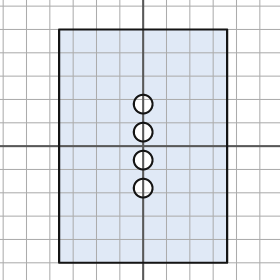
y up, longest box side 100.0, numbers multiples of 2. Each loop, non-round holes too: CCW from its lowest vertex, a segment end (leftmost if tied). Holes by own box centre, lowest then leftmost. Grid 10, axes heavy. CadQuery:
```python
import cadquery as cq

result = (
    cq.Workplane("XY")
    .moveTo(-36.0, -50.0)
    .lineTo(36.0, -50.0)
    .lineTo(36.0, 50.0)
    .lineTo(-36.0, 50.0)
    .close()
    .moveTo(0.0, -18.0)
    .circle(4.0)
    .moveTo(0.0, -6.0)
    .circle(4.0)
    .moveTo(0.0, 6.0)
    .circle(4.0)
    .moveTo(0.0, 18.0)
    .circle(4.0)
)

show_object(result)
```